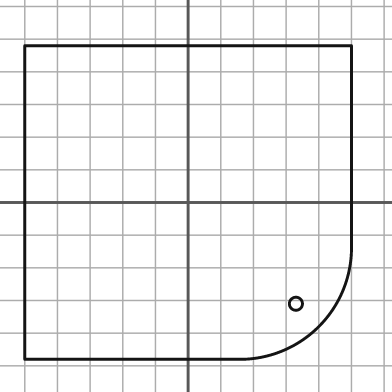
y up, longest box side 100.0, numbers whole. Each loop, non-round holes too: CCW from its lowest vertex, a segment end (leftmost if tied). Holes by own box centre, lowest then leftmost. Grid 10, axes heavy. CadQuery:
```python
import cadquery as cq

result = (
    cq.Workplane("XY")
    .moveTo(-50.0, -48.0)
    .lineTo(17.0, -48.0)
    .threePointArc((40.0, -38.0), (50.0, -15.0))
    .lineTo(50.0, 48.0)
    .lineTo(-50.0, 48.0)
    .close()
    .moveTo(33.0, -31.0)
    .circle(2.0)
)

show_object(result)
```